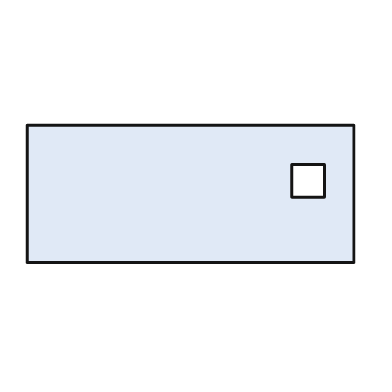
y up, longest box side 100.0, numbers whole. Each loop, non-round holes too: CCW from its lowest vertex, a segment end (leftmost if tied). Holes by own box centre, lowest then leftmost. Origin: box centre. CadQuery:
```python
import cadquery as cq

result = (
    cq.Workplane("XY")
    .moveTo(-50.0, -21.0)
    .lineTo(50.0, -21.0)
    .lineTo(50.0, 21.0)
    .lineTo(-50.0, 21.0)
    .close()
    .moveTo(31.0, -1.0)
    .lineTo(41.0, -1.0)
    .lineTo(41.0, 9.0)
    .lineTo(31.0, 9.0)
    .close()
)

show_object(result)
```